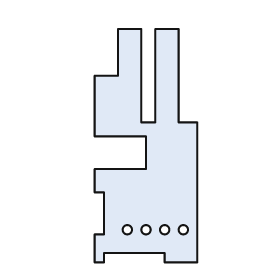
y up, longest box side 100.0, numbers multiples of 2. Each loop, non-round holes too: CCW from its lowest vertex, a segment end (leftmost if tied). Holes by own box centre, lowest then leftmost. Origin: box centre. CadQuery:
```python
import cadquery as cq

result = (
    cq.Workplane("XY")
    .moveTo(-22.0, -50.0)
    .lineTo(-18.0, -50.0)
    .lineTo(-18.0, -46.0)
    .lineTo(8.0, -46.0)
    .lineTo(8.0, -50.0)
    .lineTo(22.0, -50.0)
    .lineTo(22.0, 10.0)
    .lineTo(14.0, 10.0)
    .lineTo(14.0, 50.0)
    .lineTo(4.0, 50.0)
    .lineTo(4.0, 10.0)
    .lineTo(-2.0, 10.0)
    .lineTo(-2.0, 50.0)
    .lineTo(-12.0, 50.0)
    .lineTo(-12.0, 30.0)
    .lineTo(-22.0, 30.0)
    .lineTo(-22.0, 4.0)
    .lineTo(0.0, 4.0)
    .lineTo(0.0, -10.0)
    .lineTo(-22.0, -10.0)
    .lineTo(-22.0, -20.0)
    .lineTo(-18.0, -20.0)
    .lineTo(-18.0, -38.0)
    .lineTo(-22.0, -38.0)
    .close()
    .moveTo(-8.0, -36.0)
    .circle(2.0)
    .moveTo(0.0, -36.0)
    .circle(2.0)
    .moveTo(8.0, -36.0)
    .circle(2.0)
    .moveTo(16.0, -36.0)
    .circle(2.0)
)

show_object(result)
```